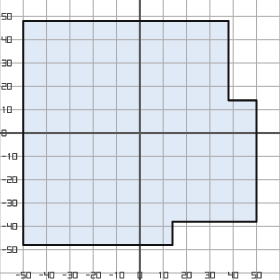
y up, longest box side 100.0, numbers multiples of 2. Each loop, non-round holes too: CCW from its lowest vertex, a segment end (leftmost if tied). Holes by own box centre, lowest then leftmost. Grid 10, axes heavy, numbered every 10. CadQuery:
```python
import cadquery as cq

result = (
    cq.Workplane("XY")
    .moveTo(-50.0, -48.0)
    .lineTo(14.0, -48.0)
    .lineTo(14.0, -38.0)
    .lineTo(50.0, -38.0)
    .lineTo(50.0, 14.0)
    .lineTo(38.0, 14.0)
    .lineTo(38.0, 48.0)
    .lineTo(-50.0, 48.0)
    .close()
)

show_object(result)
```